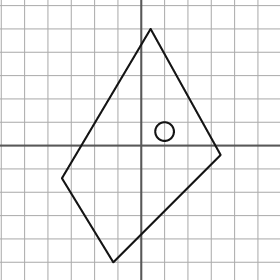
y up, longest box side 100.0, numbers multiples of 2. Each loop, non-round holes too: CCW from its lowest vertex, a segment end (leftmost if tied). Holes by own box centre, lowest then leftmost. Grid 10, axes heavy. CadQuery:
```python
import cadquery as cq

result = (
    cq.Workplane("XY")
    .moveTo(-12.0, -50.0)
    .lineTo(34.0, -4.0)
    .lineTo(4.0, 50.0)
    .lineTo(-34.0, -14.0)
    .close()
    .moveTo(10.0, 6.0)
    .circle(4.0)
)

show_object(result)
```